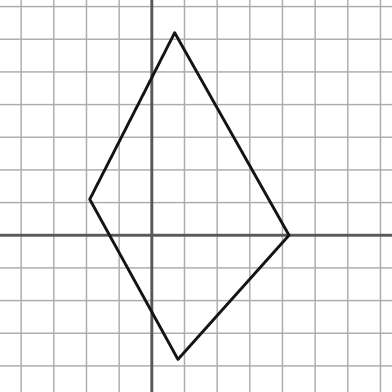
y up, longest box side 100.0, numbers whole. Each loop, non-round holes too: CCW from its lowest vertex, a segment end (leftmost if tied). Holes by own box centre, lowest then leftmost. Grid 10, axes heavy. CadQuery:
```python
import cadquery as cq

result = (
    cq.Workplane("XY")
    .moveTo(8.0, -38.0)
    .lineTo(42.0, 0.0)
    .lineTo(7.0, 62.0)
    .lineTo(-19.0, 11.0)
    .close()
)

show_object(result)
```